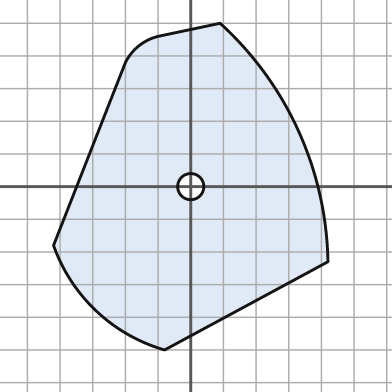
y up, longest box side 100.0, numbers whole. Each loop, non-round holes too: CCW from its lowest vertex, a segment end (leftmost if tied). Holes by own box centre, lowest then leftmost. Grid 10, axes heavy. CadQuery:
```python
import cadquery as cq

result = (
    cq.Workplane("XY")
    .moveTo(-8.0, -50.0)
    .lineTo(42.0, -23.0)
    .threePointArc((33.0, 17.0), (9.0, 50.0))
    .lineTo(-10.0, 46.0)
    .threePointArc((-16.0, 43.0), (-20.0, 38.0))
    .lineTo(-42.0, -18.0)
    .threePointArc((-29.0, -38.0), (-8.0, -50.0))
    .close()
    .moveTo(0.0, 0.0)
    .circle(4.0)
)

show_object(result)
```